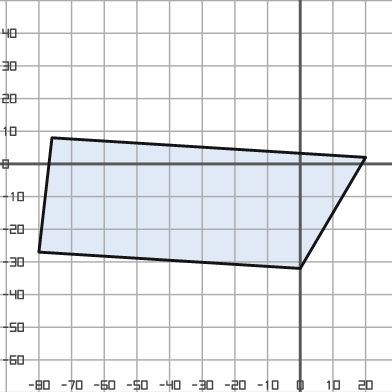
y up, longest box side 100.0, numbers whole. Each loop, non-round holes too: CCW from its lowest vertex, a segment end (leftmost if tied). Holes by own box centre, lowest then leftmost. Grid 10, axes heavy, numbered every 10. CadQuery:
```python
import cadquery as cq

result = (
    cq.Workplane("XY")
    .moveTo(0.0, -32.0)
    .lineTo(20.0, 2.0)
    .lineTo(-76.0, 8.0)
    .lineTo(-80.0, -27.0)
    .close()
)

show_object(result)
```